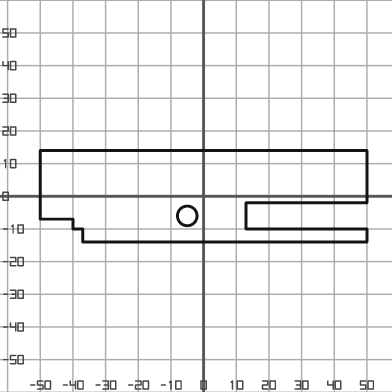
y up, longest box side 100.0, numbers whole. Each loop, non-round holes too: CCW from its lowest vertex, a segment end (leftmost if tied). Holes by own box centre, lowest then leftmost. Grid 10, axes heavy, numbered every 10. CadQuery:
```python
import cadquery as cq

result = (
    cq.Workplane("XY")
    .moveTo(-37.0, -14.0)
    .lineTo(50.0, -14.0)
    .lineTo(50.0, -10.0)
    .lineTo(13.0, -10.0)
    .lineTo(13.0, -2.0)
    .lineTo(50.0, -2.0)
    .lineTo(50.0, 14.0)
    .lineTo(-50.0, 14.0)
    .lineTo(-50.0, -7.0)
    .lineTo(-40.0, -7.0)
    .lineTo(-40.0, -10.0)
    .lineTo(-37.0, -10.0)
    .close()
    .moveTo(-5.0, -6.0)
    .circle(3.0)
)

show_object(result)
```